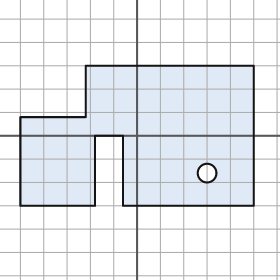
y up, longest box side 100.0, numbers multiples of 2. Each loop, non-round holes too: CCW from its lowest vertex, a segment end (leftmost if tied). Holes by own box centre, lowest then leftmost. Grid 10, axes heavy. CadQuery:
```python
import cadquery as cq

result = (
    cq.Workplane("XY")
    .moveTo(-50.0, -30.0)
    .lineTo(-18.0, -30.0)
    .lineTo(-18.0, 0.0)
    .lineTo(-6.0, 0.0)
    .lineTo(-6.0, -30.0)
    .lineTo(50.0, -30.0)
    .lineTo(50.0, 30.0)
    .lineTo(-22.0, 30.0)
    .lineTo(-22.0, 8.0)
    .lineTo(-50.0, 8.0)
    .close()
    .moveTo(30.0, -16.0)
    .circle(4.0)
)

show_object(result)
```